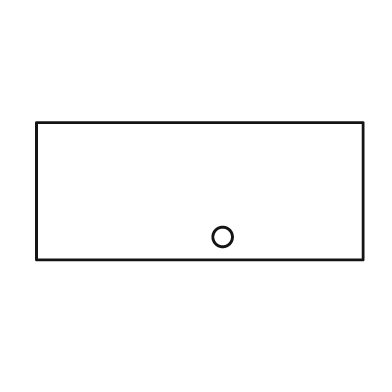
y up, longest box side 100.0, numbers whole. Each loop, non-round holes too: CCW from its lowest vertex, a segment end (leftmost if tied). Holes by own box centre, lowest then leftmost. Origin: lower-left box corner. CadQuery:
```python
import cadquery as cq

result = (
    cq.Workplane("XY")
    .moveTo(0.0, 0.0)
    .lineTo(100.0, 0.0)
    .lineTo(100.0, 42.0)
    .lineTo(0.0, 42.0)
    .close()
    .moveTo(57.0, 7.0)
    .circle(3.0)
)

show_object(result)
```